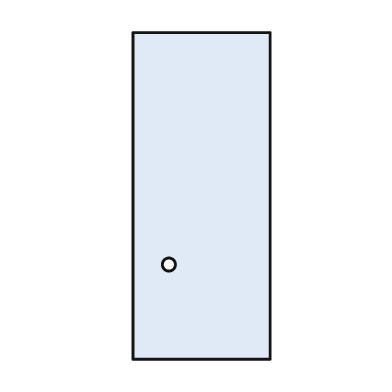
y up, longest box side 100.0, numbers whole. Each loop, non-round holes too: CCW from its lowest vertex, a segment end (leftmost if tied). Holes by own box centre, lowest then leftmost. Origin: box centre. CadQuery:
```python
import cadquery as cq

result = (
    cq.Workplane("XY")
    .moveTo(-21.0, -50.0)
    .lineTo(21.0, -50.0)
    .lineTo(21.0, 50.0)
    .lineTo(-21.0, 50.0)
    .close()
    .moveTo(-10.0, -21.0)
    .circle(2.0)
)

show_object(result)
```